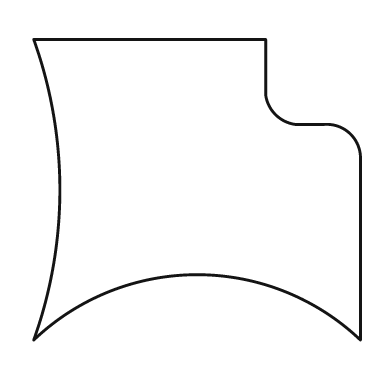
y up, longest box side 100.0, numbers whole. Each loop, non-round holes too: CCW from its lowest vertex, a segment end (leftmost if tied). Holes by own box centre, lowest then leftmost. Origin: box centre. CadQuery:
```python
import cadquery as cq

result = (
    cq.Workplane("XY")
    .moveTo(-50.0, -46.0)
    .threePointArc((0.0, -26.0), (50.0, -46.0))
    .lineTo(50.0, 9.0)
    .threePointArc((47.0, 17.0), (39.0, 20.0))
    .lineTo(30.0, 20.0)
    .threePointArc((24.0, 23.0), (21.0, 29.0))
    .lineTo(21.0, 46.0)
    .lineTo(-50.0, 46.0)
    .threePointArc((-42.0, 0.0), (-50.0, -46.0))
    .close()
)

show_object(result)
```